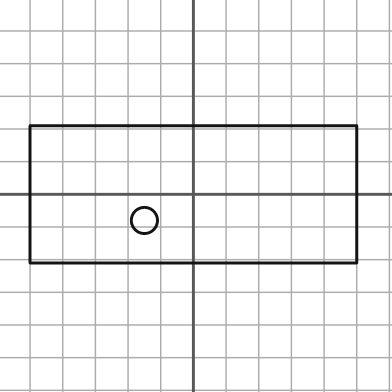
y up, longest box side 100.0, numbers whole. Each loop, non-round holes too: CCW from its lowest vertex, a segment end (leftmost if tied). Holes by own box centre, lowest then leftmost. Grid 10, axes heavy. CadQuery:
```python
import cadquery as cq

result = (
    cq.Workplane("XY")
    .moveTo(-50.0, -21.0)
    .lineTo(50.0, -21.0)
    .lineTo(50.0, 21.0)
    .lineTo(-50.0, 21.0)
    .close()
    .moveTo(-15.0, -8.0)
    .circle(4.0)
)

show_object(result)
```